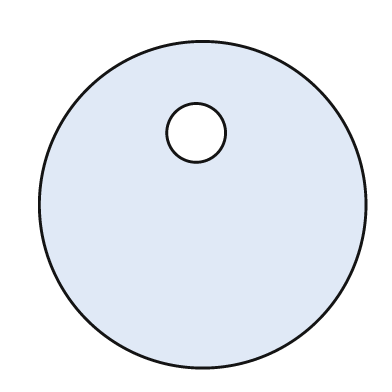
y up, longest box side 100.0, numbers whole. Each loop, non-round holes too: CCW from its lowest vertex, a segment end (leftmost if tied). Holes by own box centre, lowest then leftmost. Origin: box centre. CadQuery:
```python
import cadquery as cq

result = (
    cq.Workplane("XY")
    .moveTo(0.0, 0.0)
    .circle(50.0)
    .moveTo(-2.0, 22.0)
    .circle(9.0)
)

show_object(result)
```